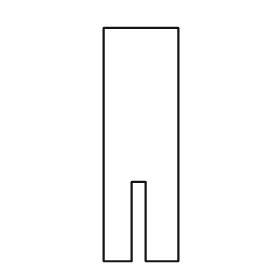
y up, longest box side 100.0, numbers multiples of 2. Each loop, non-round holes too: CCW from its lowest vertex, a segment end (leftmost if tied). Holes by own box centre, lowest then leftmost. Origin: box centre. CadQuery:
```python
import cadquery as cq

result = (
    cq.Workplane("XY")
    .moveTo(-16.0, -50.0)
    .lineTo(-4.0, -50.0)
    .lineTo(-4.0, -16.0)
    .lineTo(2.0, -16.0)
    .lineTo(2.0, -50.0)
    .lineTo(16.0, -50.0)
    .lineTo(16.0, 50.0)
    .lineTo(-16.0, 50.0)
    .close()
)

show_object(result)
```